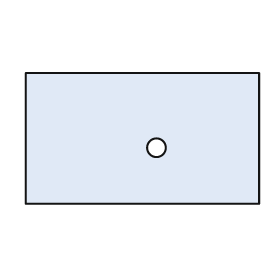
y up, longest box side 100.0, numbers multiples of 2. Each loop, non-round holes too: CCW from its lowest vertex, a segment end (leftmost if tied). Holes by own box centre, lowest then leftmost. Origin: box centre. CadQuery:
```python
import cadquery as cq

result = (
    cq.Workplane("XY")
    .moveTo(-50.0, -28.0)
    .lineTo(50.0, -28.0)
    .lineTo(50.0, 28.0)
    .lineTo(-50.0, 28.0)
    .close()
    .moveTo(6.0, -4.0)
    .circle(4.0)
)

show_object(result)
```